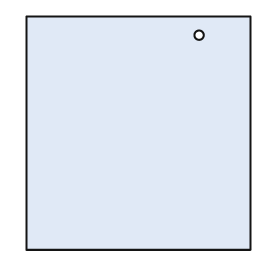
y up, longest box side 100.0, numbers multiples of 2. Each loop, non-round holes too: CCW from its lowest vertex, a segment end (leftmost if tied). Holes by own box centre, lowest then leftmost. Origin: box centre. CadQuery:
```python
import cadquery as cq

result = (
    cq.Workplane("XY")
    .moveTo(-48.0, -50.0)
    .lineTo(48.0, -50.0)
    .lineTo(48.0, 50.0)
    .lineTo(-48.0, 50.0)
    .close()
    .moveTo(26.0, 42.0)
    .circle(2.0)
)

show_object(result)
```